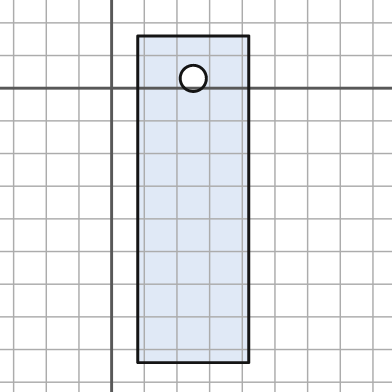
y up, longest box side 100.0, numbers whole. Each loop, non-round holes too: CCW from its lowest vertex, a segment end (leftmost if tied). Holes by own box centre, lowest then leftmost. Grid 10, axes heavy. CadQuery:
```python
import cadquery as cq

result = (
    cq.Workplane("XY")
    .moveTo(8.0, -84.0)
    .lineTo(42.0, -84.0)
    .lineTo(42.0, 16.0)
    .lineTo(8.0, 16.0)
    .close()
    .moveTo(25.0, 3.0)
    .circle(4.0)
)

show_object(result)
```